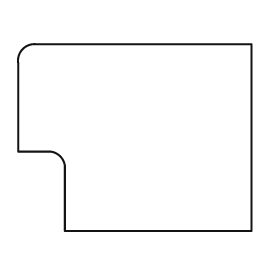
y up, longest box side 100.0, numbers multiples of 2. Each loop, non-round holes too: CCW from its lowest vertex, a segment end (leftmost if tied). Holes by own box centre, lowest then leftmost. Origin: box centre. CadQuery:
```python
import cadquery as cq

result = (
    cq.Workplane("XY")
    .moveTo(-30.0, -40.0)
    .lineTo(50.0, -40.0)
    .lineTo(50.0, 40.0)
    .lineTo(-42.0, 40.0)
    .threePointArc((-48.0, 38.0), (-50.0, 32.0))
    .lineTo(-50.0, -6.0)
    .lineTo(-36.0, -6.0)
    .threePointArc((-32.0, -8.0), (-30.0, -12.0))
    .close()
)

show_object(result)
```